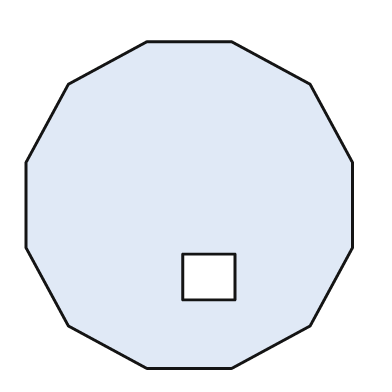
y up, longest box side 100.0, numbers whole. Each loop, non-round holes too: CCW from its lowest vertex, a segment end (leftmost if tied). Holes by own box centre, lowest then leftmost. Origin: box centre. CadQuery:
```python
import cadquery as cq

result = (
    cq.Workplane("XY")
    .moveTo(-13.0, -50.0)
    .lineTo(13.0, -50.0)
    .lineTo(37.0, -37.0)
    .lineTo(50.0, -13.0)
    .lineTo(50.0, 13.0)
    .lineTo(37.0, 37.0)
    .lineTo(13.0, 50.0)
    .lineTo(-13.0, 50.0)
    .lineTo(-37.0, 37.0)
    .lineTo(-50.0, 13.0)
    .lineTo(-50.0, -13.0)
    .lineTo(-37.0, -37.0)
    .close()
    .moveTo(-2.0, -29.0)
    .lineTo(14.0, -29.0)
    .lineTo(14.0, -15.0)
    .lineTo(-2.0, -15.0)
    .close()
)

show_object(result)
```